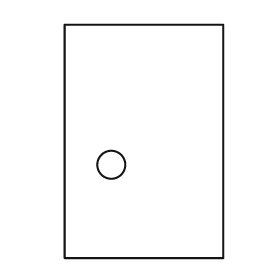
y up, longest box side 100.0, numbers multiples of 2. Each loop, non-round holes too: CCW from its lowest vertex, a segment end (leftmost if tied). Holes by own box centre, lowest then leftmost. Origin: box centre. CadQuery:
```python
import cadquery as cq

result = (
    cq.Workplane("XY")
    .moveTo(-34.0, -50.0)
    .lineTo(34.0, -50.0)
    .lineTo(34.0, 50.0)
    .lineTo(-34.0, 50.0)
    .close()
    .moveTo(-14.0, -10.0)
    .circle(6.0)
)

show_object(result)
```